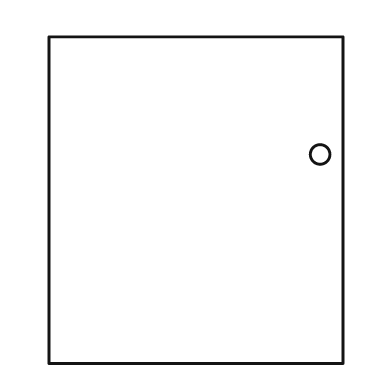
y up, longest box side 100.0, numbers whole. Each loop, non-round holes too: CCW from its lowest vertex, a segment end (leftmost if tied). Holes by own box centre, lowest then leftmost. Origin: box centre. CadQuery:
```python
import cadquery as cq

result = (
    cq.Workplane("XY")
    .moveTo(-45.0, -50.0)
    .lineTo(45.0, -50.0)
    .lineTo(45.0, 50.0)
    .lineTo(-45.0, 50.0)
    .close()
    .moveTo(38.0, 14.0)
    .circle(3.0)
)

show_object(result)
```